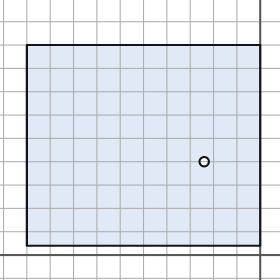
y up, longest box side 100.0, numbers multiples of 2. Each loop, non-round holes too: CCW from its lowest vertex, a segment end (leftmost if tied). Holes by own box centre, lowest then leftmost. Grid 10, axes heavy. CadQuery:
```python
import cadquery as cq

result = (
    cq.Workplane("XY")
    .moveTo(-100.0, 4.0)
    .lineTo(0.0, 4.0)
    .lineTo(0.0, 90.0)
    .lineTo(-100.0, 90.0)
    .close()
    .moveTo(-24.0, 40.0)
    .circle(2.0)
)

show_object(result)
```